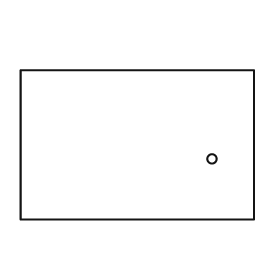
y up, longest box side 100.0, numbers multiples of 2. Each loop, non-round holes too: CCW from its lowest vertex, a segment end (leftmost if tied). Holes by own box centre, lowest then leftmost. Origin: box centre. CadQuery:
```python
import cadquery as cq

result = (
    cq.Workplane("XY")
    .moveTo(-50.0, -32.0)
    .lineTo(50.0, -32.0)
    .lineTo(50.0, 32.0)
    .lineTo(-50.0, 32.0)
    .close()
    .moveTo(32.0, -6.0)
    .circle(2.0)
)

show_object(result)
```